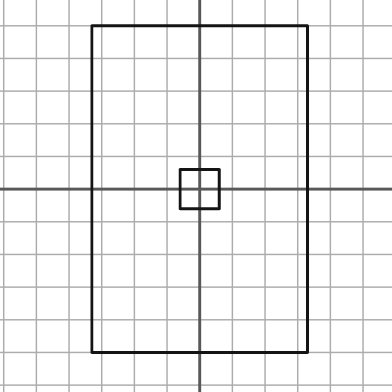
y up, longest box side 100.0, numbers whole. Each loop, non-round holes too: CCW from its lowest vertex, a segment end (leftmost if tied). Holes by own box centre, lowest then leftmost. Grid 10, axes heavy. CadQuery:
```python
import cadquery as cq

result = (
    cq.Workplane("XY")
    .moveTo(-33.0, -50.0)
    .lineTo(33.0, -50.0)
    .lineTo(33.0, 50.0)
    .lineTo(-33.0, 50.0)
    .close()
    .moveTo(-6.0, -6.0)
    .lineTo(6.0, -6.0)
    .lineTo(6.0, 6.0)
    .lineTo(-6.0, 6.0)
    .close()
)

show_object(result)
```